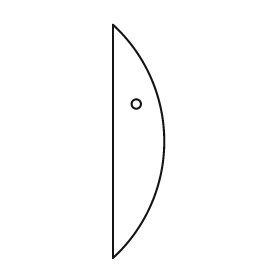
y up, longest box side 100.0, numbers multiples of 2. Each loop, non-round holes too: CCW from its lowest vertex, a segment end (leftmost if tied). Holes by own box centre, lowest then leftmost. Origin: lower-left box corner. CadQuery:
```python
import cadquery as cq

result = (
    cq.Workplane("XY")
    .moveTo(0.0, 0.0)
    .threePointArc((22.0, 50.0), (0.0, 100.0))
    .close()
    .moveTo(10.0, 66.0)
    .circle(2.0)
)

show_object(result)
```